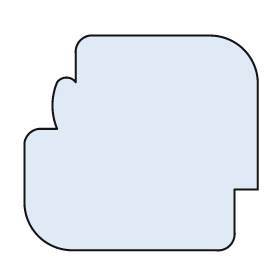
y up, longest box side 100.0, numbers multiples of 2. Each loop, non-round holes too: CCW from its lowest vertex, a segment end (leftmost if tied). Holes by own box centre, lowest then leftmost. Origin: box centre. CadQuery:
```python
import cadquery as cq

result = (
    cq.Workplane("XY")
    .moveTo(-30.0, -46.0)
    .lineTo(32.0, -46.0)
    .threePointArc((38.0, -44.0), (40.0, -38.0))
    .lineTo(40.0, -20.0)
    .lineTo(50.0, -20.0)
    .lineTo(50.0, 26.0)
    .threePointArc((44.0, 40.0), (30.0, 46.0))
    .lineTo(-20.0, 46.0)
    .threePointArc((-26.0, 44.0), (-28.0, 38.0))
    .lineTo(-28.0, 26.0)
    .threePointArc((-32.0, 28.0), (-36.0, 26.0))
    .threePointArc((-38.0, 16.0), (-36.0, 6.0))
    .lineTo(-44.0, 6.0)
    .threePointArc((-48.0, 4.0), (-50.0, 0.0))
    .lineTo(-50.0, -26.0)
    .threePointArc((-44.0, -40.0), (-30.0, -46.0))
    .close()
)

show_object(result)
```